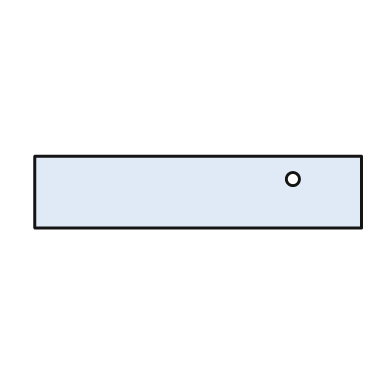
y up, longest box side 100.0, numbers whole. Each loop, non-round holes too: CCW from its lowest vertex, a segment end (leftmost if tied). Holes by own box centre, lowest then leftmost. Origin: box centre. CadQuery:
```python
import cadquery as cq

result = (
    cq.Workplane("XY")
    .moveTo(-50.0, -11.0)
    .lineTo(50.0, -11.0)
    .lineTo(50.0, 11.0)
    .lineTo(-50.0, 11.0)
    .close()
    .moveTo(29.0, 4.0)
    .circle(2.0)
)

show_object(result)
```